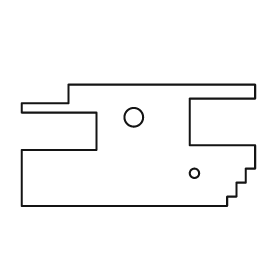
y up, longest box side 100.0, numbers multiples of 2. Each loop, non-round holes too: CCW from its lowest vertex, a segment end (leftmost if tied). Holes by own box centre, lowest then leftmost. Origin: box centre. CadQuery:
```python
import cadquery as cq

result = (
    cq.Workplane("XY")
    .moveTo(-50.0, -26.0)
    .lineTo(38.0, -26.0)
    .lineTo(38.0, -22.0)
    .lineTo(42.0, -22.0)
    .lineTo(42.0, -16.0)
    .lineTo(46.0, -16.0)
    .lineTo(46.0, -10.0)
    .lineTo(50.0, -10.0)
    .lineTo(50.0, 0.0)
    .lineTo(22.0, 0.0)
    .lineTo(22.0, 20.0)
    .lineTo(50.0, 20.0)
    .lineTo(50.0, 26.0)
    .lineTo(-30.0, 26.0)
    .lineTo(-30.0, 18.0)
    .lineTo(-50.0, 18.0)
    .lineTo(-50.0, 14.0)
    .lineTo(-18.0, 14.0)
    .lineTo(-18.0, -2.0)
    .lineTo(-50.0, -2.0)
    .close()
    .moveTo(24.0, -12.0)
    .circle(2.0)
    .moveTo(-2.0, 12.0)
    .circle(4.0)
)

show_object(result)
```